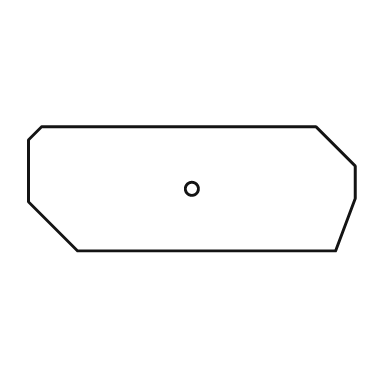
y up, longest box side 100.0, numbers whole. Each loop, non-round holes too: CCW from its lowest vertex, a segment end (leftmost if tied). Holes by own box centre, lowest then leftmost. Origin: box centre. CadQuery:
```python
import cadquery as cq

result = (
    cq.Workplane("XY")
    .moveTo(-35.0, -19.0)
    .lineTo(44.0, -19.0)
    .lineTo(50.0, -3.0)
    .lineTo(50.0, 7.0)
    .lineTo(38.0, 19.0)
    .lineTo(-46.0, 19.0)
    .lineTo(-50.0, 15.0)
    .lineTo(-50.0, -4.0)
    .close()
    .moveTo(0.0, 0.0)
    .circle(2.0)
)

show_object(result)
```